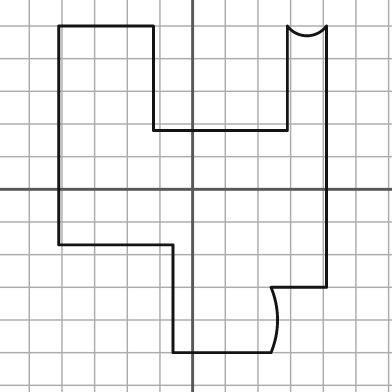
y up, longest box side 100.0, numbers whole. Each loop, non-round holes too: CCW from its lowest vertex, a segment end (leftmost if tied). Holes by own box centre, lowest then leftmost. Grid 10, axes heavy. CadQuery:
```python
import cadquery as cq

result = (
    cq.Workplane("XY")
    .moveTo(-6.0, -50.0)
    .lineTo(24.0, -50.0)
    .threePointArc((26.0, -40.0), (24.0, -30.0))
    .lineTo(41.0, -30.0)
    .lineTo(41.0, 50.0)
    .threePointArc((35.0, 47.0), (29.0, 50.0))
    .lineTo(29.0, 18.0)
    .lineTo(-12.0, 18.0)
    .lineTo(-12.0, 50.0)
    .lineTo(-41.0, 50.0)
    .lineTo(-41.0, -17.0)
    .lineTo(-6.0, -17.0)
    .close()
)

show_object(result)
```